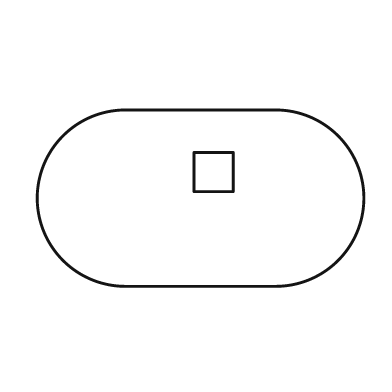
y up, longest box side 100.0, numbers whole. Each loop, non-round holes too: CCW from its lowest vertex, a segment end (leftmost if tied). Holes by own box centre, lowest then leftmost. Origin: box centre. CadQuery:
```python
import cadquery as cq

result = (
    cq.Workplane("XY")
    .moveTo(-23.0, -27.0)
    .lineTo(23.0, -27.0)
    .threePointArc((50.0, 0.0), (23.0, 27.0))
    .lineTo(-23.0, 27.0)
    .threePointArc((-50.0, 0.0), (-23.0, -27.0))
    .close()
    .moveTo(-2.0, 2.0)
    .lineTo(10.0, 2.0)
    .lineTo(10.0, 14.0)
    .lineTo(-2.0, 14.0)
    .close()
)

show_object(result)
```